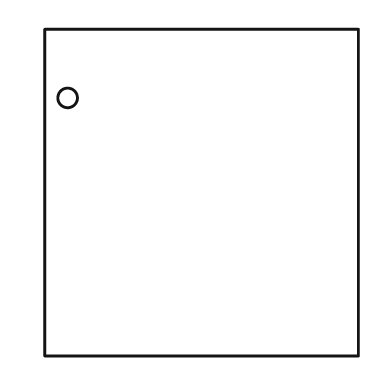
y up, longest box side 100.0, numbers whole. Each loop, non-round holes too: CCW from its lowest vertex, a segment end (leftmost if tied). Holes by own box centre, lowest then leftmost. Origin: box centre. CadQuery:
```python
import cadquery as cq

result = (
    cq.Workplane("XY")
    .moveTo(-48.0, -50.0)
    .lineTo(48.0, -50.0)
    .lineTo(48.0, 50.0)
    .lineTo(-48.0, 50.0)
    .close()
    .moveTo(-41.0, 29.0)
    .circle(3.0)
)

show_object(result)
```